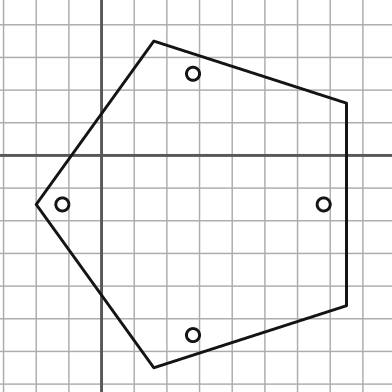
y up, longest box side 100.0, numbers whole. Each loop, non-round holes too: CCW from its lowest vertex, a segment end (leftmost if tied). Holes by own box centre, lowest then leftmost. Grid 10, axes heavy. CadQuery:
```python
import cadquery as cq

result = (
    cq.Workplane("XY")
    .moveTo(16.0, -65.0)
    .lineTo(75.0, -46.0)
    .lineTo(75.0, 16.0)
    .lineTo(16.0, 35.0)
    .lineTo(-20.0, -15.0)
    .close()
    .moveTo(28.0, -55.0)
    .circle(2.0)
    .moveTo(-12.0, -15.0)
    .circle(2.0)
    .moveTo(68.0, -15.0)
    .circle(2.0)
    .moveTo(28.0, 25.0)
    .circle(2.0)
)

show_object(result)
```